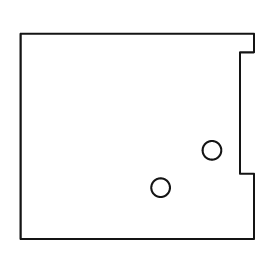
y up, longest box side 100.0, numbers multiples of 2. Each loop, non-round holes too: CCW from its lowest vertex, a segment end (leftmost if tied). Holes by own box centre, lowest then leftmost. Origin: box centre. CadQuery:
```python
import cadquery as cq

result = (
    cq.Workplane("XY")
    .moveTo(-50.0, -44.0)
    .lineTo(50.0, -44.0)
    .lineTo(50.0, -16.0)
    .lineTo(44.0, -16.0)
    .lineTo(44.0, 36.0)
    .lineTo(50.0, 36.0)
    .lineTo(50.0, 44.0)
    .lineTo(-50.0, 44.0)
    .close()
    .moveTo(10.0, -22.0)
    .circle(4.0)
    .moveTo(32.0, -6.0)
    .circle(4.0)
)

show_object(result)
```